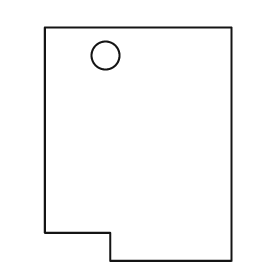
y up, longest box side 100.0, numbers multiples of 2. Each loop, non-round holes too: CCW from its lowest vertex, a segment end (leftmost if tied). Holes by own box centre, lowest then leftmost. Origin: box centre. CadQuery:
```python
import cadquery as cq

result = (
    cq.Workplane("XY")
    .moveTo(-12.0, -50.0)
    .lineTo(40.0, -50.0)
    .lineTo(40.0, 50.0)
    .lineTo(-40.0, 50.0)
    .lineTo(-40.0, -38.0)
    .lineTo(-12.0, -38.0)
    .close()
    .moveTo(-14.0, 38.0)
    .circle(6.0)
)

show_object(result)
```